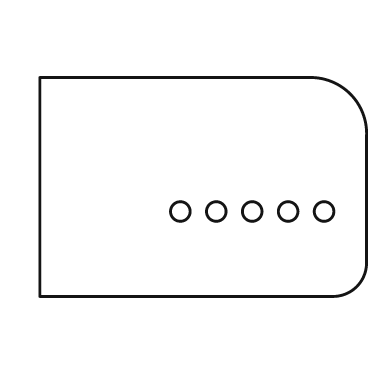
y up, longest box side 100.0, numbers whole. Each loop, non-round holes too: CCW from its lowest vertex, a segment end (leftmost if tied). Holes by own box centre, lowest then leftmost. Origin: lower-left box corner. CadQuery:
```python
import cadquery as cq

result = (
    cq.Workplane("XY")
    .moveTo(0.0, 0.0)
    .lineTo(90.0, 0.0)
    .threePointArc((97.0, 3.0), (100.0, 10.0))
    .lineTo(100.0, 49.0)
    .threePointArc((95.0, 62.0), (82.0, 67.0))
    .lineTo(0.0, 67.0)
    .close()
    .moveTo(43.0, 26.0)
    .circle(3.0)
    .moveTo(54.0, 26.0)
    .circle(3.0)
    .moveTo(65.0, 26.0)
    .circle(3.0)
    .moveTo(76.0, 26.0)
    .circle(3.0)
    .moveTo(87.0, 26.0)
    .circle(3.0)
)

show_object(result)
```